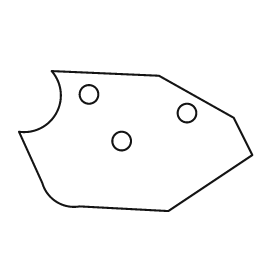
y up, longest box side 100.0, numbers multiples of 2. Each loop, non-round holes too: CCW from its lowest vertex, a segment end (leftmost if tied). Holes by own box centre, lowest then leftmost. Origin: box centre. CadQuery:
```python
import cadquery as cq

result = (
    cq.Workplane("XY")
    .moveTo(14.0, -30.0)
    .lineTo(50.0, -6.0)
    .lineTo(42.0, 10.0)
    .lineTo(10.0, 28.0)
    .lineTo(-36.0, 30.0)
    .threePointArc((-34.0, 12.0), (-50.0, 4.0))
    .lineTo(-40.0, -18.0)
    .threePointArc((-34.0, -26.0), (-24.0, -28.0))
    .close()
    .moveTo(-6.0, 0.0)
    .circle(4.0)
    .moveTo(22.0, 12.0)
    .circle(4.0)
    .moveTo(-20.0, 20.0)
    .circle(4.0)
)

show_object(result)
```